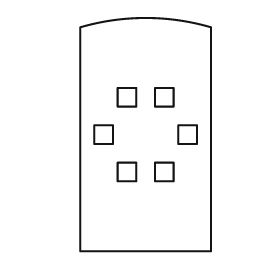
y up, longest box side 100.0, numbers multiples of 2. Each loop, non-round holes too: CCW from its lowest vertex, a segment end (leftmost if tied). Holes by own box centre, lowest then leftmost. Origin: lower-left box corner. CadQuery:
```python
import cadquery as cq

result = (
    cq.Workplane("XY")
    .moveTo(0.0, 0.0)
    .lineTo(56.0, 0.0)
    .lineTo(56.0, 96.0)
    .threePointArc((28.0, 100.0), (0.0, 96.0))
    .close()
    .moveTo(16.0, 30.0)
    .lineTo(24.0, 30.0)
    .lineTo(24.0, 38.0)
    .lineTo(16.0, 38.0)
    .close()
    .moveTo(32.0, 30.0)
    .lineTo(40.0, 30.0)
    .lineTo(40.0, 38.0)
    .lineTo(32.0, 38.0)
    .close()
    .moveTo(6.0, 46.0)
    .lineTo(14.0, 46.0)
    .lineTo(14.0, 54.0)
    .lineTo(6.0, 54.0)
    .close()
    .moveTo(42.0, 46.0)
    .lineTo(50.0, 46.0)
    .lineTo(50.0, 54.0)
    .lineTo(42.0, 54.0)
    .close()
    .moveTo(16.0, 62.0)
    .lineTo(24.0, 62.0)
    .lineTo(24.0, 70.0)
    .lineTo(16.0, 70.0)
    .close()
    .moveTo(32.0, 62.0)
    .lineTo(40.0, 62.0)
    .lineTo(40.0, 70.0)
    .lineTo(32.0, 70.0)
    .close()
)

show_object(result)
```